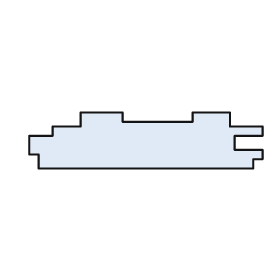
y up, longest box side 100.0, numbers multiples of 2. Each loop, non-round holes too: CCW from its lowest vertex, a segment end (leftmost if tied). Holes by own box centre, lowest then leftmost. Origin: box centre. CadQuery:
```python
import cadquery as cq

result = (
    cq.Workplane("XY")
    .moveTo(-46.0, -12.0)
    .lineTo(46.0, -12.0)
    .lineTo(46.0, -8.0)
    .lineTo(50.0, -8.0)
    .lineTo(50.0, -4.0)
    .lineTo(38.0, -4.0)
    .lineTo(38.0, 2.0)
    .lineTo(50.0, 2.0)
    .lineTo(50.0, 6.0)
    .lineTo(36.0, 6.0)
    .lineTo(36.0, 12.0)
    .lineTo(20.0, 12.0)
    .lineTo(20.0, 8.0)
    .lineTo(-10.0, 8.0)
    .lineTo(-10.0, 12.0)
    .lineTo(-28.0, 12.0)
    .lineTo(-28.0, 6.0)
    .lineTo(-40.0, 6.0)
    .lineTo(-40.0, 2.0)
    .lineTo(-50.0, 2.0)
    .lineTo(-50.0, -6.0)
    .lineTo(-46.0, -6.0)
    .close()
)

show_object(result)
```